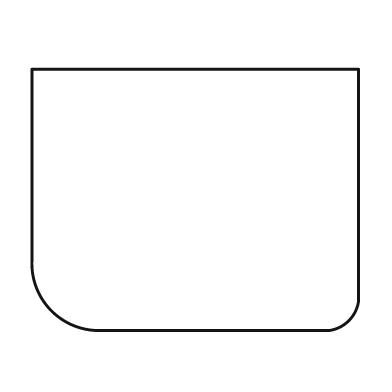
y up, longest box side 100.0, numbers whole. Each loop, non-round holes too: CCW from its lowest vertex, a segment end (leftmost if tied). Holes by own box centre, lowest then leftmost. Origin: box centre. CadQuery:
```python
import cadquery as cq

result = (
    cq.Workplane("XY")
    .moveTo(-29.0, -40.0)
    .lineTo(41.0, -40.0)
    .threePointArc((47.0, -37.0), (50.0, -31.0))
    .lineTo(50.0, 40.0)
    .lineTo(-50.0, 40.0)
    .lineTo(-50.0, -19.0)
    .threePointArc((-44.0, -34.0), (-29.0, -40.0))
    .close()
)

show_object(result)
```